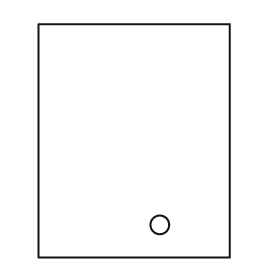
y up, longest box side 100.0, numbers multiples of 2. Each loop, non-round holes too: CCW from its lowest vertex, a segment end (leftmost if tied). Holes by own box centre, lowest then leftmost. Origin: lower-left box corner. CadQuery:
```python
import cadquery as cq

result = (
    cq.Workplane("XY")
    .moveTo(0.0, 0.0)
    .lineTo(82.0, 0.0)
    .lineTo(82.0, 100.0)
    .lineTo(0.0, 100.0)
    .close()
    .moveTo(52.0, 14.0)
    .circle(4.0)
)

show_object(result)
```